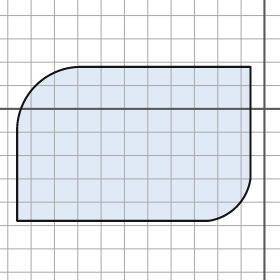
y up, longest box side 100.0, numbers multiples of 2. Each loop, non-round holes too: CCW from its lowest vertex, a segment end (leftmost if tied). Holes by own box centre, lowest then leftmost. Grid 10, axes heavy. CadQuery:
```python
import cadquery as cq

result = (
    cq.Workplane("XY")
    .moveTo(-106.0, -48.0)
    .lineTo(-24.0, -48.0)
    .threePointArc((-12.0, -42.0), (-6.0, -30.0))
    .lineTo(-6.0, 18.0)
    .lineTo(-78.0, 18.0)
    .threePointArc((-98.0, 10.0), (-106.0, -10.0))
    .close()
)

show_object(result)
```